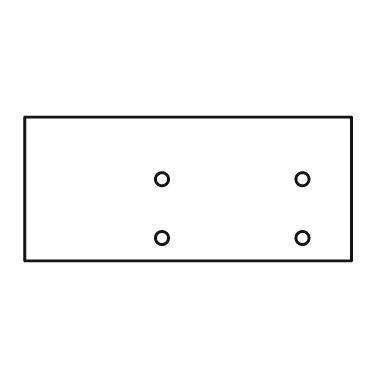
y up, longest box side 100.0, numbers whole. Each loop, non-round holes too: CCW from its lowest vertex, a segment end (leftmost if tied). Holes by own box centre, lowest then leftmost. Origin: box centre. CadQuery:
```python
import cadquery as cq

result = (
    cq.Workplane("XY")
    .moveTo(-50.0, -22.0)
    .lineTo(50.0, -22.0)
    .lineTo(50.0, 22.0)
    .lineTo(-50.0, 22.0)
    .close()
    .moveTo(-8.0, -15.0)
    .circle(2.0)
    .moveTo(35.0, -15.0)
    .circle(2.0)
    .moveTo(-8.0, 3.0)
    .circle(2.0)
    .moveTo(35.0, 3.0)
    .circle(2.0)
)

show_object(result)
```